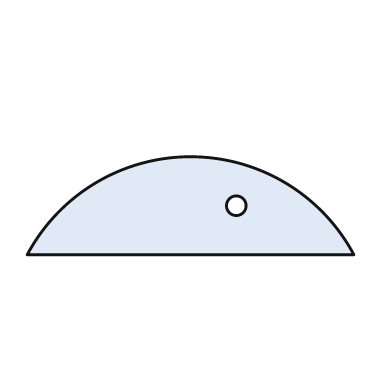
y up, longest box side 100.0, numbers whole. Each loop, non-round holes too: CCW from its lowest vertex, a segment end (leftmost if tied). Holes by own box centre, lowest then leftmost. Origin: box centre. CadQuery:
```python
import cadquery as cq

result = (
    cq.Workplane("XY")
    .moveTo(-50.0, -15.0)
    .lineTo(50.0, -15.0)
    .threePointArc((0.0, 15.0), (-50.0, -15.0))
    .close()
    .moveTo(14.0, 0.0)
    .circle(3.0)
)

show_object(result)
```